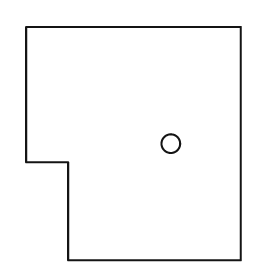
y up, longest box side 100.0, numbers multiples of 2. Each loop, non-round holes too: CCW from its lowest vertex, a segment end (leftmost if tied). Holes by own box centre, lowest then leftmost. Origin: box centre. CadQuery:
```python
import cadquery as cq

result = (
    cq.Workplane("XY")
    .moveTo(-28.0, -50.0)
    .lineTo(46.0, -50.0)
    .lineTo(46.0, 50.0)
    .lineTo(-46.0, 50.0)
    .lineTo(-46.0, -8.0)
    .lineTo(-28.0, -8.0)
    .close()
    .moveTo(16.0, 0.0)
    .circle(4.0)
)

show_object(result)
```